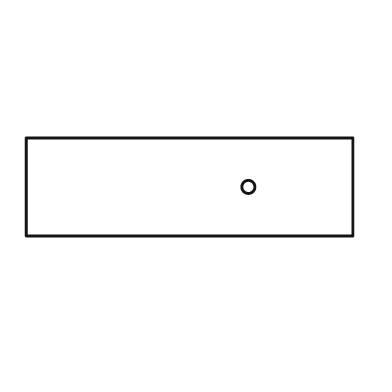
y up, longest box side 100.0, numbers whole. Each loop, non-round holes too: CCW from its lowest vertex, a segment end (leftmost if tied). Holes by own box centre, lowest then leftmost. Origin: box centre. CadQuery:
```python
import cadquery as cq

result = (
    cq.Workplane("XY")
    .moveTo(-50.0, -15.0)
    .lineTo(50.0, -15.0)
    .lineTo(50.0, 15.0)
    .lineTo(-50.0, 15.0)
    .close()
    .moveTo(18.0, 0.0)
    .circle(2.0)
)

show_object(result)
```